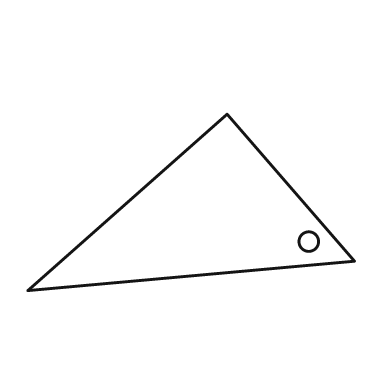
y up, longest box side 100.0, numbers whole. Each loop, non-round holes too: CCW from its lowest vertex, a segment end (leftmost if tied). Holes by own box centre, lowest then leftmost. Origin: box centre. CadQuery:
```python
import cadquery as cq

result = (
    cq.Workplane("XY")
    .moveTo(-50.0, -27.0)
    .lineTo(50.0, -18.0)
    .lineTo(11.0, 27.0)
    .close()
    .moveTo(36.0, -12.0)
    .circle(3.0)
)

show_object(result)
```